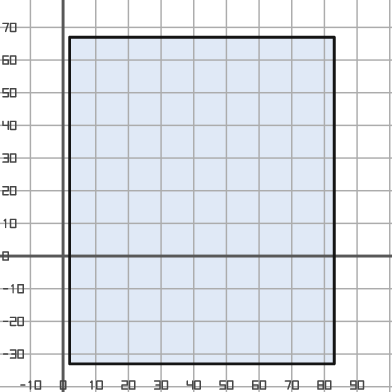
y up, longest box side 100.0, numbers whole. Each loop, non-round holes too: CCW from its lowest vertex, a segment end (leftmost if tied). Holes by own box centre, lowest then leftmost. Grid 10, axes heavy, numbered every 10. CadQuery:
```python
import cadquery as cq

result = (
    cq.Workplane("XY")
    .moveTo(2.0, -33.0)
    .lineTo(83.0, -33.0)
    .lineTo(83.0, 67.0)
    .lineTo(2.0, 67.0)
    .close()
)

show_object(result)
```